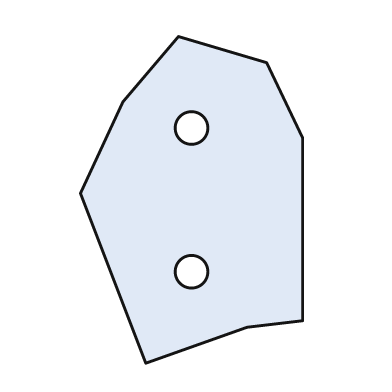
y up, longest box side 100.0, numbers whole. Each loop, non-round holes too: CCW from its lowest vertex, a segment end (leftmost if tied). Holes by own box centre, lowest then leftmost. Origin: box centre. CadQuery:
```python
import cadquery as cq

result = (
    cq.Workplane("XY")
    .moveTo(-14.0, -50.0)
    .lineTo(17.0, -39.0)
    .lineTo(34.0, -37.0)
    .lineTo(34.0, 19.0)
    .lineTo(23.0, 42.0)
    .lineTo(-4.0, 50.0)
    .lineTo(-21.0, 30.0)
    .lineTo(-34.0, 2.0)
    .close()
    .moveTo(0.0, -22.0)
    .circle(5.0)
    .moveTo(0.0, 22.0)
    .circle(5.0)
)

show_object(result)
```